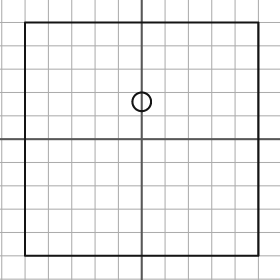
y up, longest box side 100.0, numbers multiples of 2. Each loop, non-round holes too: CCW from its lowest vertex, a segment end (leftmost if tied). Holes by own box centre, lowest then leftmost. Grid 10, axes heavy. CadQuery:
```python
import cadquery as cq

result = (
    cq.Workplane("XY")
    .moveTo(-50.0, -50.0)
    .lineTo(50.0, -50.0)
    .lineTo(50.0, 50.0)
    .lineTo(-50.0, 50.0)
    .close()
    .moveTo(0.0, 16.0)
    .circle(4.0)
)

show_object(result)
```